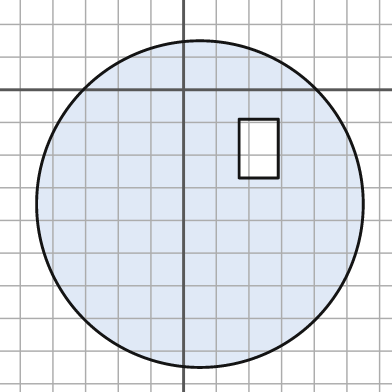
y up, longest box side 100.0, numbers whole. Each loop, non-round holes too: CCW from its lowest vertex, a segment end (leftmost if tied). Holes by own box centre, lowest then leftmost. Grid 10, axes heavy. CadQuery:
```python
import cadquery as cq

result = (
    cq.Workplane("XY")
    .moveTo(5.0, -35.0)
    .circle(50.0)
    .moveTo(17.0, -27.0)
    .lineTo(29.0, -27.0)
    .lineTo(29.0, -9.0)
    .lineTo(17.0, -9.0)
    .close()
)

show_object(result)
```